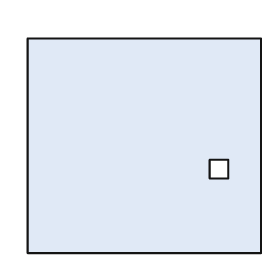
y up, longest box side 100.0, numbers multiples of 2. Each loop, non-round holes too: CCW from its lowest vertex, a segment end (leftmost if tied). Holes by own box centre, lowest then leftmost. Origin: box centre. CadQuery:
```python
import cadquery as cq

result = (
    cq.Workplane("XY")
    .moveTo(-50.0, -46.0)
    .lineTo(50.0, -46.0)
    .lineTo(50.0, 46.0)
    .lineTo(-50.0, 46.0)
    .close()
    .moveTo(28.0, -14.0)
    .lineTo(36.0, -14.0)
    .lineTo(36.0, -6.0)
    .lineTo(28.0, -6.0)
    .close()
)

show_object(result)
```